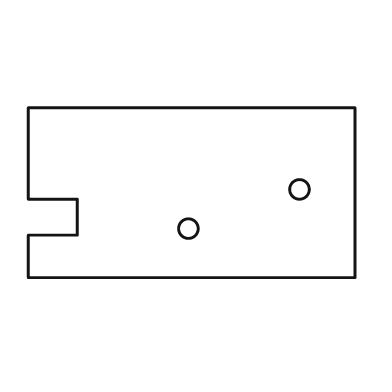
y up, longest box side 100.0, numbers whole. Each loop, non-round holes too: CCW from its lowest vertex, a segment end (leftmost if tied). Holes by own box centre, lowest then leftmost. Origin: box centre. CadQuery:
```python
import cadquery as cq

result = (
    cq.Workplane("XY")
    .moveTo(-50.0, -26.0)
    .lineTo(50.0, -26.0)
    .lineTo(50.0, 26.0)
    .lineTo(-50.0, 26.0)
    .lineTo(-50.0, -2.0)
    .lineTo(-35.0, -2.0)
    .lineTo(-35.0, -13.0)
    .lineTo(-50.0, -13.0)
    .close()
    .moveTo(-1.0, -11.0)
    .circle(3.0)
    .moveTo(33.0, 1.0)
    .circle(3.0)
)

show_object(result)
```